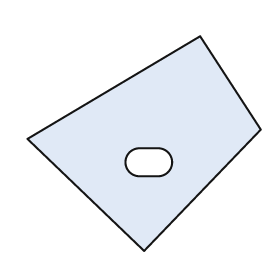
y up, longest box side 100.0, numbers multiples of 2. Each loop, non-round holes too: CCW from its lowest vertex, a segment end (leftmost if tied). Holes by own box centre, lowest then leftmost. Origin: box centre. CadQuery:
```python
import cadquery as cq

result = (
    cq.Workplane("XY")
    .moveTo(0.0, -46.0)
    .lineTo(50.0, 6.0)
    .lineTo(24.0, 46.0)
    .lineTo(-50.0, 2.0)
    .close()
    .moveTo(-2.0, -14.0)
    .lineTo(6.0, -14.0)
    .threePointArc((12.0, -8.0), (6.0, -2.0))
    .lineTo(-2.0, -2.0)
    .threePointArc((-8.0, -8.0), (-2.0, -14.0))
    .close()
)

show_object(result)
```